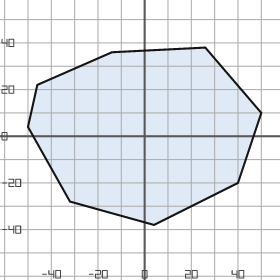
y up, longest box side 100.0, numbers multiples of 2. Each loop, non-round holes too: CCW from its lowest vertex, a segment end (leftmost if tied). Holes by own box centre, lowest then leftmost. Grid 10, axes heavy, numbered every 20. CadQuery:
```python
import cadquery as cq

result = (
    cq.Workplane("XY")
    .moveTo(4.0, -38.0)
    .lineTo(40.0, -20.0)
    .lineTo(50.0, 10.0)
    .lineTo(26.0, 38.0)
    .lineTo(-14.0, 36.0)
    .lineTo(-46.0, 22.0)
    .lineTo(-50.0, 4.0)
    .lineTo(-32.0, -28.0)
    .close()
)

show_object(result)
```